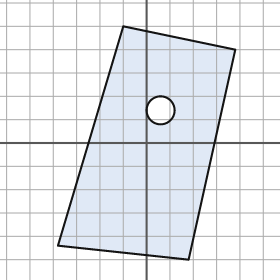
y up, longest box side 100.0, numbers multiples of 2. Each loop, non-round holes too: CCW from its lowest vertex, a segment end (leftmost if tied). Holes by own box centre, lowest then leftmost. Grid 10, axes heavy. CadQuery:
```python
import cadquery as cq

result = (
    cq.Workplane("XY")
    .moveTo(18.0, -50.0)
    .lineTo(38.0, 40.0)
    .lineTo(-10.0, 50.0)
    .lineTo(-38.0, -44.0)
    .close()
    .moveTo(6.0, 14.0)
    .circle(6.0)
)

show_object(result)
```